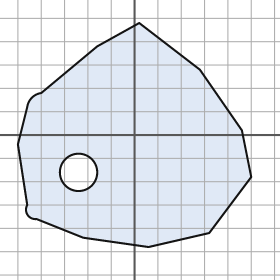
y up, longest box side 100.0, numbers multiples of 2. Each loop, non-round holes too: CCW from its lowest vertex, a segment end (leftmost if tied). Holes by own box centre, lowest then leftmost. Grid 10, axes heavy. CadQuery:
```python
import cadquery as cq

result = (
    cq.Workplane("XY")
    .moveTo(6.0, -48.0)
    .lineTo(32.0, -42.0)
    .lineTo(50.0, -18.0)
    .lineTo(46.0, 2.0)
    .lineTo(28.0, 28.0)
    .lineTo(2.0, 48.0)
    .lineTo(-16.0, 38.0)
    .lineTo(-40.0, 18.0)
    .threePointArc((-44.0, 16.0), (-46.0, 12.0))
    .lineTo(-50.0, -4.0)
    .lineTo(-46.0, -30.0)
    .threePointArc((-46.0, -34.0), (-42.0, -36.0))
    .lineTo(-22.0, -44.0)
    .close()
    .moveTo(-24.0, -16.0)
    .circle(8.0)
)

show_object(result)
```